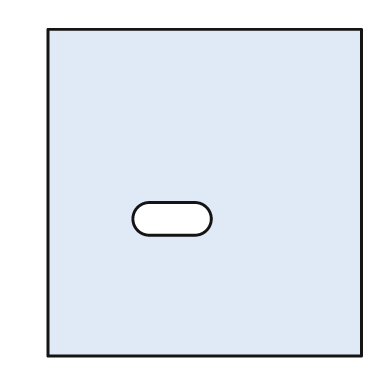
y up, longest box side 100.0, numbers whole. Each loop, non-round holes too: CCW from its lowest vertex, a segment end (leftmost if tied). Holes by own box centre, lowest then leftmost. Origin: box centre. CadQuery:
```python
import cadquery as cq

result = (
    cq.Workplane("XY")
    .moveTo(-48.0, -50.0)
    .lineTo(48.0, -50.0)
    .lineTo(48.0, 50.0)
    .lineTo(-48.0, 50.0)
    .close()
    .moveTo(-17.0, -13.0)
    .lineTo(-3.0, -13.0)
    .threePointArc((2.0, -8.0), (-3.0, -3.0))
    .lineTo(-17.0, -3.0)
    .threePointArc((-22.0, -8.0), (-17.0, -13.0))
    .close()
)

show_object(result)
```